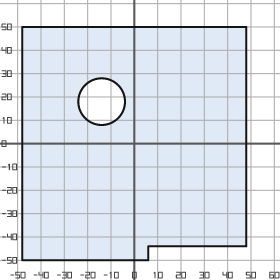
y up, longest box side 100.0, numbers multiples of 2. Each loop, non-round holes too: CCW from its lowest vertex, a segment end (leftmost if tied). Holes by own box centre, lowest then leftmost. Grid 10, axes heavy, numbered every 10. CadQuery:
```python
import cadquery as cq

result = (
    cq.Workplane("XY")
    .moveTo(-48.0, -50.0)
    .lineTo(6.0, -50.0)
    .lineTo(6.0, -44.0)
    .lineTo(48.0, -44.0)
    .lineTo(48.0, 50.0)
    .lineTo(-48.0, 50.0)
    .close()
    .moveTo(-14.0, 18.0)
    .circle(10.0)
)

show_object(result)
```